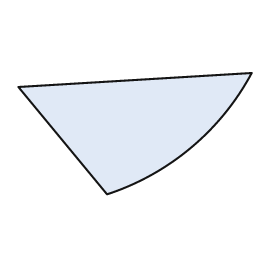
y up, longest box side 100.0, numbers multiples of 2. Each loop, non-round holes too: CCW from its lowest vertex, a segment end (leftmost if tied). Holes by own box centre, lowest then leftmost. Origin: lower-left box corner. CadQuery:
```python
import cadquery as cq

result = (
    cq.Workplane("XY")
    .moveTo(38.0, 0.0)
    .threePointArc((74.0, 20.0), (100.0, 52.0))
    .lineTo(0.0, 46.0)
    .close()
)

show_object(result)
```